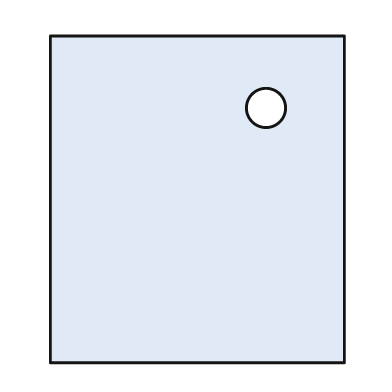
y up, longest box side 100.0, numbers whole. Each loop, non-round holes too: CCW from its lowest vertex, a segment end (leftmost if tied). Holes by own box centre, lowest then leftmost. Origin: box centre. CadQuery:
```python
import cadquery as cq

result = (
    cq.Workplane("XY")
    .moveTo(-45.0, -50.0)
    .lineTo(45.0, -50.0)
    .lineTo(45.0, 50.0)
    .lineTo(-45.0, 50.0)
    .close()
    .moveTo(21.0, 28.0)
    .circle(6.0)
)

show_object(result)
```